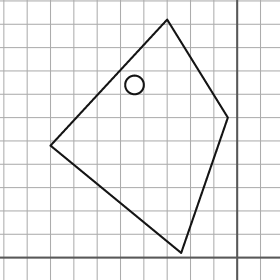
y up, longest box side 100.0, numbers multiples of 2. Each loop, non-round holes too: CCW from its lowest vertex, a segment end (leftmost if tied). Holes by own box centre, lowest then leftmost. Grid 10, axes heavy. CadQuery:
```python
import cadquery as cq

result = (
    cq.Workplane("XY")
    .moveTo(-24.0, 2.0)
    .lineTo(-4.0, 60.0)
    .lineTo(-30.0, 102.0)
    .lineTo(-80.0, 48.0)
    .close()
    .moveTo(-44.0, 74.0)
    .circle(4.0)
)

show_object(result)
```